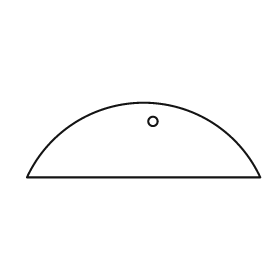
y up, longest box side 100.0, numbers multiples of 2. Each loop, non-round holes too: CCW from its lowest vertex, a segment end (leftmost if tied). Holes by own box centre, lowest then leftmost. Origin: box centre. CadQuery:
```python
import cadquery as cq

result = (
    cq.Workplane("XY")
    .moveTo(-50.0, -16.0)
    .lineTo(50.0, -16.0)
    .threePointArc((0.0, 16.0), (-50.0, -16.0))
    .close()
    .moveTo(4.0, 8.0)
    .circle(2.0)
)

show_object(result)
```